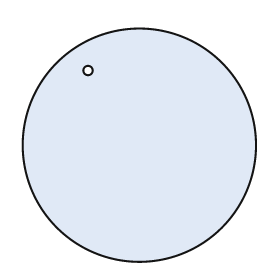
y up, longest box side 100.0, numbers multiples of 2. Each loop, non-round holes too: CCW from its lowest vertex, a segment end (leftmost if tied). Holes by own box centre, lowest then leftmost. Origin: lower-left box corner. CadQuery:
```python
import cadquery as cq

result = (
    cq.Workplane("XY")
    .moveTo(50.0, 50.0)
    .circle(50.0)
    .moveTo(28.0, 82.0)
    .circle(2.0)
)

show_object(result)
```